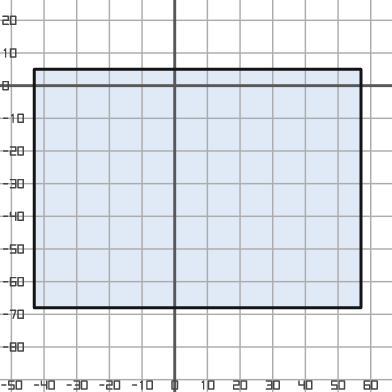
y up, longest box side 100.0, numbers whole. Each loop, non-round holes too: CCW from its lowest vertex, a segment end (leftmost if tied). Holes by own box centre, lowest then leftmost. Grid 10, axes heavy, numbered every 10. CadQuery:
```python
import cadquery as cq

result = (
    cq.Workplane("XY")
    .moveTo(-43.0, -68.0)
    .lineTo(57.0, -68.0)
    .lineTo(57.0, 5.0)
    .lineTo(-43.0, 5.0)
    .close()
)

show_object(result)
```